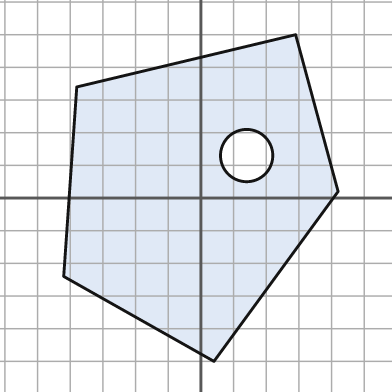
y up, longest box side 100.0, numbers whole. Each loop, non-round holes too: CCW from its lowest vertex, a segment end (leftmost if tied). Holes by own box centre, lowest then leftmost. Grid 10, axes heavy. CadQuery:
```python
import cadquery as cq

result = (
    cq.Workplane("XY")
    .moveTo(4.0, -50.0)
    .lineTo(42.0, 2.0)
    .lineTo(29.0, 50.0)
    .lineTo(-38.0, 34.0)
    .lineTo(-42.0, -24.0)
    .close()
    .moveTo(14.0, 13.0)
    .circle(8.0)
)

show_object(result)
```